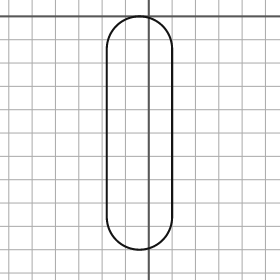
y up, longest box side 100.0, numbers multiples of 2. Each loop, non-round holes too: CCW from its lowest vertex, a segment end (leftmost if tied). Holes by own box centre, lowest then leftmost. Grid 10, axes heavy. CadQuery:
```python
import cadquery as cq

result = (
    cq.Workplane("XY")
    .moveTo(-18.0, -86.0)
    .threePointArc((-4.0, -100.0), (10.0, -86.0))
    .lineTo(10.0, -14.0)
    .threePointArc((-4.0, 0.0), (-18.0, -14.0))
    .close()
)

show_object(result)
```